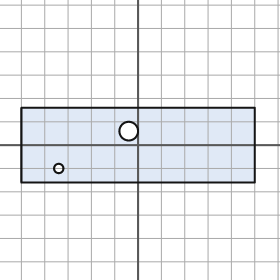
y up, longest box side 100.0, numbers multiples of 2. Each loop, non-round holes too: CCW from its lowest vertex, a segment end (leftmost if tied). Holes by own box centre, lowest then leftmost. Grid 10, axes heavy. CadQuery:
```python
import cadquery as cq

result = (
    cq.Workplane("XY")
    .moveTo(-50.0, -16.0)
    .lineTo(50.0, -16.0)
    .lineTo(50.0, 16.0)
    .lineTo(-50.0, 16.0)
    .close()
    .moveTo(-34.0, -10.0)
    .circle(2.0)
    .moveTo(-4.0, 6.0)
    .circle(4.0)
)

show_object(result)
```